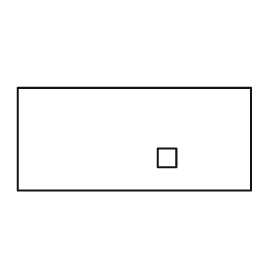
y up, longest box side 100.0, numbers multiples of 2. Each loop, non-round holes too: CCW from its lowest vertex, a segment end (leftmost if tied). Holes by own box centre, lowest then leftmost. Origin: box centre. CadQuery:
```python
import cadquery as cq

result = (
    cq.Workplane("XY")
    .moveTo(-50.0, -22.0)
    .lineTo(50.0, -22.0)
    .lineTo(50.0, 22.0)
    .lineTo(-50.0, 22.0)
    .close()
    .moveTo(10.0, -12.0)
    .lineTo(18.0, -12.0)
    .lineTo(18.0, -4.0)
    .lineTo(10.0, -4.0)
    .close()
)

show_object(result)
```